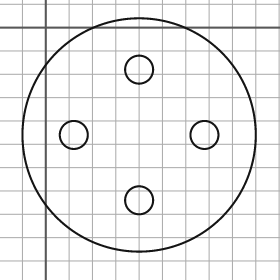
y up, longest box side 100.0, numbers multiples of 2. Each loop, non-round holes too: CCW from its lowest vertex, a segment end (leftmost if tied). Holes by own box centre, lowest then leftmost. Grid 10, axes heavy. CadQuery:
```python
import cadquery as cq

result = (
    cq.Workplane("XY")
    .moveTo(40.0, -46.0)
    .circle(50.0)
    .moveTo(40.0, -74.0)
    .circle(6.0)
    .moveTo(12.0, -46.0)
    .circle(6.0)
    .moveTo(68.0, -46.0)
    .circle(6.0)
    .moveTo(40.0, -18.0)
    .circle(6.0)
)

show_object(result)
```